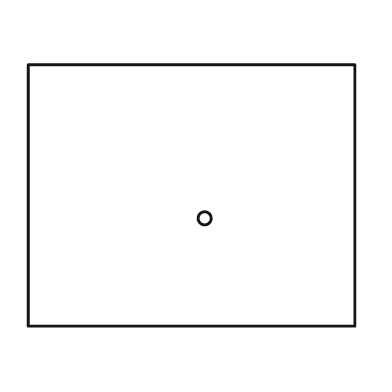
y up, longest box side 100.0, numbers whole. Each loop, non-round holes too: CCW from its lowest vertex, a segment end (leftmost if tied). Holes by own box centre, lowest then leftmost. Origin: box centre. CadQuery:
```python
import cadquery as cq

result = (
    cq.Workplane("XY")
    .moveTo(-50.0, -40.0)
    .lineTo(50.0, -40.0)
    .lineTo(50.0, 40.0)
    .lineTo(-50.0, 40.0)
    .close()
    .moveTo(4.0, -7.0)
    .circle(2.0)
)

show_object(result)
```